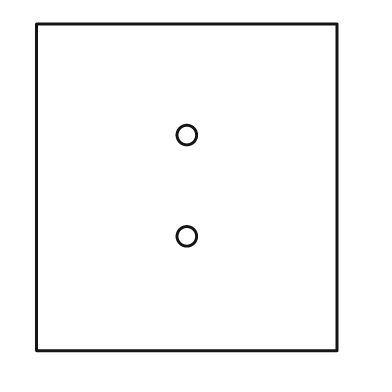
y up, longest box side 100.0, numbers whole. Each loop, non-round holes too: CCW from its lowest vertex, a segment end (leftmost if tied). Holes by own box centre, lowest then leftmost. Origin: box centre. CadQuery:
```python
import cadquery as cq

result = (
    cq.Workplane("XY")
    .moveTo(-46.0, -50.0)
    .lineTo(46.0, -50.0)
    .lineTo(46.0, 50.0)
    .lineTo(-46.0, 50.0)
    .close()
    .moveTo(0.0, -15.0)
    .circle(3.0)
    .moveTo(0.0, 16.0)
    .circle(3.0)
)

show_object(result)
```